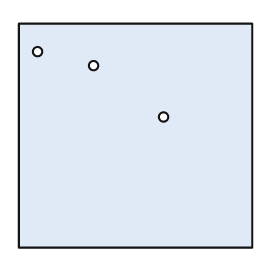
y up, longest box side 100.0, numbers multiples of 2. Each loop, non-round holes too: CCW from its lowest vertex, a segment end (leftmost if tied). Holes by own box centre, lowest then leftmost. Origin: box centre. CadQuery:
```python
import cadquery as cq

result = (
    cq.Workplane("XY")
    .moveTo(-50.0, -48.0)
    .lineTo(50.0, -48.0)
    .lineTo(50.0, 48.0)
    .lineTo(-50.0, 48.0)
    .close()
    .moveTo(12.0, 8.0)
    .circle(2.0)
    .moveTo(-18.0, 30.0)
    .circle(2.0)
    .moveTo(-42.0, 36.0)
    .circle(2.0)
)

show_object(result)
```